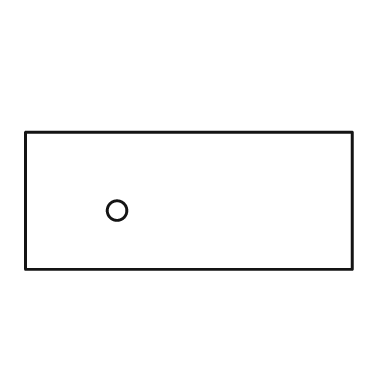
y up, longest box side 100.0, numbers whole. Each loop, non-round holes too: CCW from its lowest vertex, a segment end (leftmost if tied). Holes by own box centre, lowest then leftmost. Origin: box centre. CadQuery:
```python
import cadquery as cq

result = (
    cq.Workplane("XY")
    .moveTo(-50.0, -21.0)
    .lineTo(50.0, -21.0)
    .lineTo(50.0, 21.0)
    .lineTo(-50.0, 21.0)
    .close()
    .moveTo(-22.0, -3.0)
    .circle(3.0)
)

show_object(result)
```